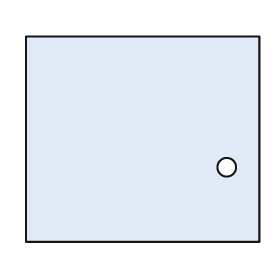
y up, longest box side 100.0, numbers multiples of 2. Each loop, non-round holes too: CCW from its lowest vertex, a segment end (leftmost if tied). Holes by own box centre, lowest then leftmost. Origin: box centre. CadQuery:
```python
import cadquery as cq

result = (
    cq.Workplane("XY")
    .moveTo(-50.0, -44.0)
    .lineTo(50.0, -44.0)
    .lineTo(50.0, 44.0)
    .lineTo(-50.0, 44.0)
    .close()
    .moveTo(36.0, -12.0)
    .circle(4.0)
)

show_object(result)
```